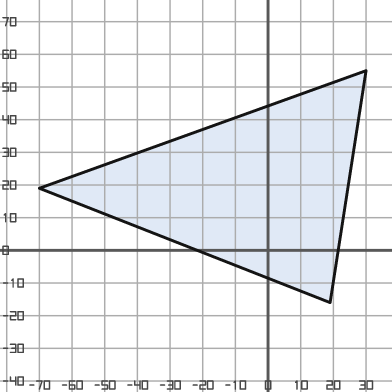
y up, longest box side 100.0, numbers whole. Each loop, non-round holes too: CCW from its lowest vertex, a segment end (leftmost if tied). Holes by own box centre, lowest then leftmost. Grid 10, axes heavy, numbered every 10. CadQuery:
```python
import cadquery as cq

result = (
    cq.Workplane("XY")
    .moveTo(19.0, -16.0)
    .lineTo(30.0, 55.0)
    .lineTo(-70.0, 19.0)
    .close()
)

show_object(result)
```